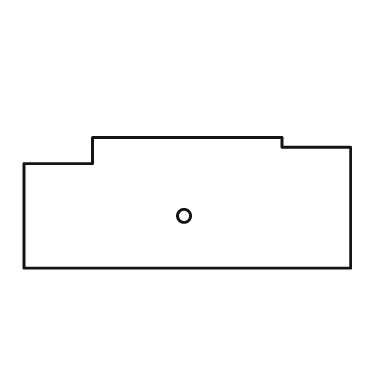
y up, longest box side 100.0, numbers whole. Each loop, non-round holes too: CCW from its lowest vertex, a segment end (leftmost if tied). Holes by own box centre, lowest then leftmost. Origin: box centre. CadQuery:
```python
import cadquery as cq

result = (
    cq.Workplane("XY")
    .moveTo(-50.0, -20.0)
    .lineTo(50.0, -20.0)
    .lineTo(50.0, 17.0)
    .lineTo(29.0, 17.0)
    .lineTo(29.0, 20.0)
    .lineTo(-29.0, 20.0)
    .lineTo(-29.0, 12.0)
    .lineTo(-50.0, 12.0)
    .close()
    .moveTo(-1.0, -4.0)
    .circle(2.0)
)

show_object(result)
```